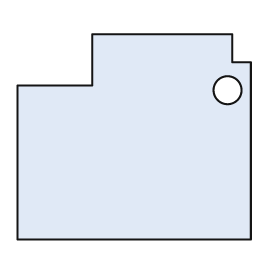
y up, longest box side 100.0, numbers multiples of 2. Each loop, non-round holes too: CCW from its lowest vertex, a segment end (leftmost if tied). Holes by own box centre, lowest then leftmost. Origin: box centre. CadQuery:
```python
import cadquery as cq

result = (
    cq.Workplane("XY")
    .moveTo(-50.0, -44.0)
    .lineTo(50.0, -44.0)
    .lineTo(50.0, 32.0)
    .lineTo(42.0, 32.0)
    .lineTo(42.0, 44.0)
    .lineTo(-18.0, 44.0)
    .lineTo(-18.0, 22.0)
    .lineTo(-50.0, 22.0)
    .close()
    .moveTo(40.0, 20.0)
    .circle(6.0)
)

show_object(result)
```